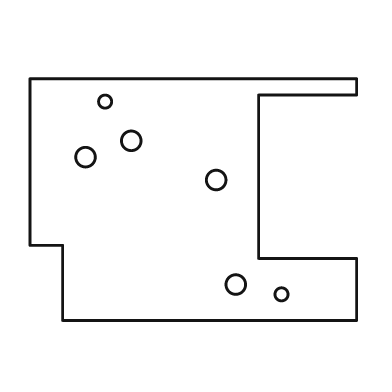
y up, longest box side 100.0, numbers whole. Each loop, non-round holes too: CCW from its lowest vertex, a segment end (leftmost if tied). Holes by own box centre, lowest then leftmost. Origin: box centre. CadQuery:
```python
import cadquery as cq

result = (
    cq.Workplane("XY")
    .moveTo(-40.0, -37.0)
    .lineTo(50.0, -37.0)
    .lineTo(50.0, -18.0)
    .lineTo(20.0, -18.0)
    .lineTo(20.0, 32.0)
    .lineTo(50.0, 32.0)
    .lineTo(50.0, 37.0)
    .lineTo(-50.0, 37.0)
    .lineTo(-50.0, -14.0)
    .lineTo(-40.0, -14.0)
    .close()
    .moveTo(27.0, -29.0)
    .circle(2.0)
    .moveTo(13.0, -26.0)
    .circle(3.0)
    .moveTo(7.0, 6.0)
    .circle(3.0)
    .moveTo(-33.0, 13.0)
    .circle(3.0)
    .moveTo(-19.0, 18.0)
    .circle(3.0)
    .moveTo(-27.0, 30.0)
    .circle(2.0)
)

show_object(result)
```